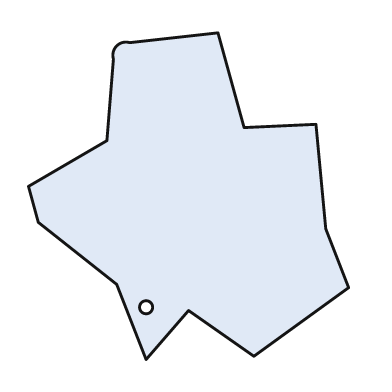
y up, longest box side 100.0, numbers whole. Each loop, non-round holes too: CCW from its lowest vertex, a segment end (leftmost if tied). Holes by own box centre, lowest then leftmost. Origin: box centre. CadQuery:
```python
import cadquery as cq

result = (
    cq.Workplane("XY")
    .moveTo(-13.0, -50.0)
    .lineTo(0.0, -35.0)
    .lineTo(20.0, -49.0)
    .lineTo(49.0, -28.0)
    .lineTo(42.0, -10.0)
    .lineTo(39.0, 22.0)
    .lineTo(17.0, 21.0)
    .lineTo(9.0, 50.0)
    .lineTo(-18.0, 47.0)
    .threePointArc((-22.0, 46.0), (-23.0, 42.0))
    .lineTo(-25.0, 17.0)
    .lineTo(-49.0, 3.0)
    .lineTo(-46.0, -8.0)
    .lineTo(-22.0, -27.0)
    .close()
    .moveTo(-13.0, -34.0)
    .circle(2.0)
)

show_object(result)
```